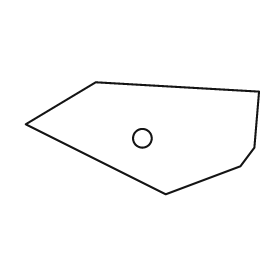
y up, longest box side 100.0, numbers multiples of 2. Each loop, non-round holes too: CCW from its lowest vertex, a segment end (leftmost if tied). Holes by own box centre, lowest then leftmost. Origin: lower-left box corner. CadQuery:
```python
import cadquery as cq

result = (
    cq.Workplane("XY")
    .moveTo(60.0, 0.0)
    .lineTo(92.0, 12.0)
    .lineTo(98.0, 20.0)
    .lineTo(100.0, 44.0)
    .lineTo(30.0, 48.0)
    .lineTo(0.0, 30.0)
    .close()
    .moveTo(50.0, 24.0)
    .circle(4.0)
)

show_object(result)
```